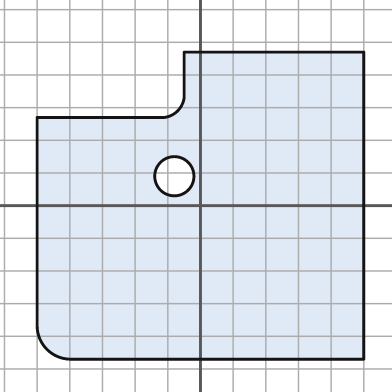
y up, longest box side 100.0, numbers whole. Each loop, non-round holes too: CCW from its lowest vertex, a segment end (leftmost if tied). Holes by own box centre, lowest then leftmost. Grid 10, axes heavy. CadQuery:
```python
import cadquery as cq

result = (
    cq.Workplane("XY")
    .moveTo(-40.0, -47.0)
    .lineTo(50.0, -47.0)
    .lineTo(50.0, 47.0)
    .lineTo(-5.0, 47.0)
    .lineTo(-5.0, 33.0)
    .threePointArc((-7.0, 29.0), (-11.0, 27.0))
    .lineTo(-50.0, 27.0)
    .lineTo(-50.0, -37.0)
    .threePointArc((-47.0, -44.0), (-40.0, -47.0))
    .close()
    .moveTo(-8.0, 9.0)
    .circle(6.0)
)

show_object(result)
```